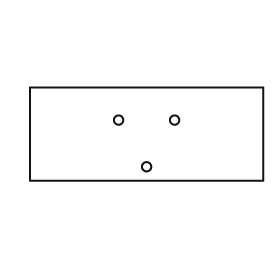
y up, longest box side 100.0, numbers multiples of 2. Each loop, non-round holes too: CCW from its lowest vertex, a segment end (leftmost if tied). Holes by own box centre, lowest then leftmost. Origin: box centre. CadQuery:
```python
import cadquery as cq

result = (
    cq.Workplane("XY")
    .moveTo(-50.0, -20.0)
    .lineTo(50.0, -20.0)
    .lineTo(50.0, 20.0)
    .lineTo(-50.0, 20.0)
    .close()
    .moveTo(0.0, -14.0)
    .circle(2.0)
    .moveTo(-12.0, 6.0)
    .circle(2.0)
    .moveTo(12.0, 6.0)
    .circle(2.0)
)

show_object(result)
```